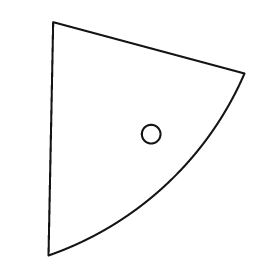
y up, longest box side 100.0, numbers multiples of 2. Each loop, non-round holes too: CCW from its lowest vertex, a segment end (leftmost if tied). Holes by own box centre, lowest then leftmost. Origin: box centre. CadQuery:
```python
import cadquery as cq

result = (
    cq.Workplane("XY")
    .moveTo(-42.0, -50.0)
    .threePointArc((8.0, -20.0), (42.0, 28.0))
    .lineTo(-40.0, 50.0)
    .close()
    .moveTo(2.0, 2.0)
    .circle(4.0)
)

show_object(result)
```